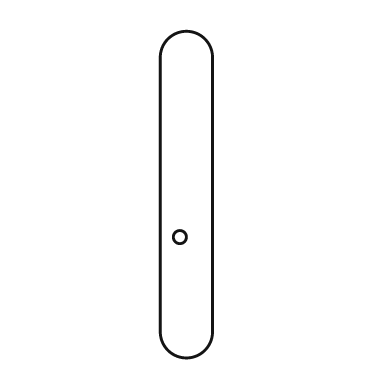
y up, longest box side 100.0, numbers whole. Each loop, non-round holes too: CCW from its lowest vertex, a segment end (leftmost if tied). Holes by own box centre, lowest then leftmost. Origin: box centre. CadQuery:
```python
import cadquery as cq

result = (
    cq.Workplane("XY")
    .moveTo(-8.0, -42.0)
    .threePointArc((0.0, -50.0), (8.0, -42.0))
    .lineTo(8.0, 42.0)
    .threePointArc((0.0, 50.0), (-8.0, 42.0))
    .close()
    .moveTo(-2.0, -13.0)
    .circle(2.0)
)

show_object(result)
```